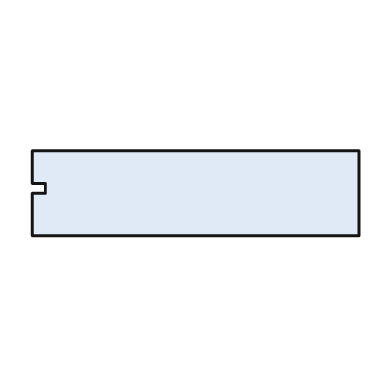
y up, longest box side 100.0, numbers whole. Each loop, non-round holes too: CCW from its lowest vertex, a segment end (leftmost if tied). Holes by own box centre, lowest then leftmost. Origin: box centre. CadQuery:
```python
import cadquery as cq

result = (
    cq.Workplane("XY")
    .moveTo(-50.0, -13.0)
    .lineTo(50.0, -13.0)
    .lineTo(50.0, 13.0)
    .lineTo(-50.0, 13.0)
    .lineTo(-50.0, 3.0)
    .lineTo(-46.0, 3.0)
    .lineTo(-46.0, 0.0)
    .lineTo(-50.0, 0.0)
    .close()
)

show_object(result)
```